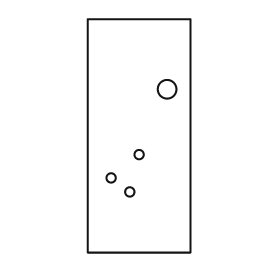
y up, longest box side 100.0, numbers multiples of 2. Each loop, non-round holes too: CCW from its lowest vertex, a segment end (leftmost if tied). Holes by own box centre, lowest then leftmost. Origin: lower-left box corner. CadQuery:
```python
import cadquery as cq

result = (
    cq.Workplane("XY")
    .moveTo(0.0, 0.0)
    .lineTo(44.0, 0.0)
    .lineTo(44.0, 100.0)
    .lineTo(0.0, 100.0)
    .close()
    .moveTo(18.0, 26.0)
    .circle(2.0)
    .moveTo(10.0, 32.0)
    .circle(2.0)
    .moveTo(22.0, 42.0)
    .circle(2.0)
    .moveTo(34.0, 70.0)
    .circle(4.0)
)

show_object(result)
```